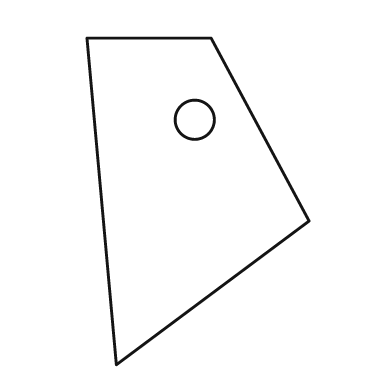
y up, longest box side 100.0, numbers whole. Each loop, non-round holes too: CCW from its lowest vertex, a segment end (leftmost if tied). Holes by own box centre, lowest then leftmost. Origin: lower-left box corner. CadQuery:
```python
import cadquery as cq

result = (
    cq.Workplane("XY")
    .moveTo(9.0, 0.0)
    .lineTo(68.0, 44.0)
    .lineTo(38.0, 100.0)
    .lineTo(0.0, 100.0)
    .close()
    .moveTo(33.0, 75.0)
    .circle(6.0)
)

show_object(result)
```